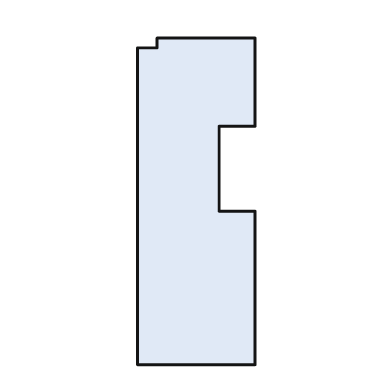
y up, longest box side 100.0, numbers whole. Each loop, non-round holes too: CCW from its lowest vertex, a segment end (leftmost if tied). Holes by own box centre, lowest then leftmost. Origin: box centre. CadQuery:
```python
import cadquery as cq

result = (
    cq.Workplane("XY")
    .moveTo(-18.0, -50.0)
    .lineTo(18.0, -50.0)
    .lineTo(18.0, -3.0)
    .lineTo(7.0, -3.0)
    .lineTo(7.0, 23.0)
    .lineTo(18.0, 23.0)
    .lineTo(18.0, 50.0)
    .lineTo(-12.0, 50.0)
    .lineTo(-12.0, 47.0)
    .lineTo(-18.0, 47.0)
    .close()
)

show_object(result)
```